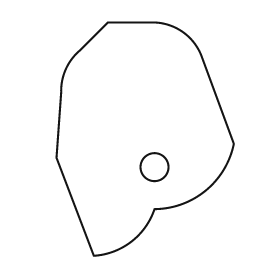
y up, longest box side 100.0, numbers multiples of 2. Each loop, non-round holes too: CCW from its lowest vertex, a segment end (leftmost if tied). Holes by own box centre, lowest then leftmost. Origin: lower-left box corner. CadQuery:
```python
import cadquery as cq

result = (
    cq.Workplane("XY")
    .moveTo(16.0, 0.0)
    .threePointArc((32.0, 6.0), (42.0, 20.0))
    .threePointArc((64.0, 28.0), (76.0, 48.0))
    .lineTo(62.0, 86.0)
    .threePointArc((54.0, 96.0), (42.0, 100.0))
    .lineTo(22.0, 100.0)
    .lineTo(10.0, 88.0)
    .threePointArc((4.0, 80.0), (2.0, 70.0))
    .lineTo(0.0, 42.0)
    .close()
    .moveTo(42.0, 38.0)
    .circle(6.0)
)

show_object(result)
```